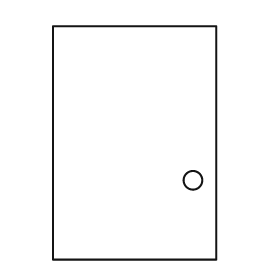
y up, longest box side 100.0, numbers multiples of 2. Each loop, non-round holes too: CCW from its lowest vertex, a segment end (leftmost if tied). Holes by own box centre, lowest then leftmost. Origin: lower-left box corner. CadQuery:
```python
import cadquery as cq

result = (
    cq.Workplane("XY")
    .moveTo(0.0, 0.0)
    .lineTo(70.0, 0.0)
    .lineTo(70.0, 100.0)
    .lineTo(0.0, 100.0)
    .close()
    .moveTo(60.0, 34.0)
    .circle(4.0)
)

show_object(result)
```